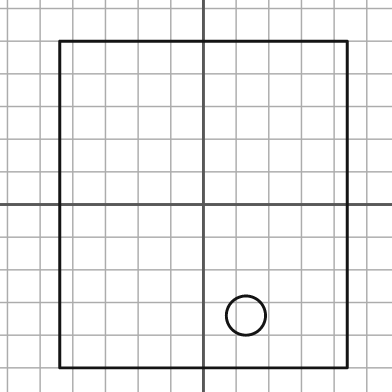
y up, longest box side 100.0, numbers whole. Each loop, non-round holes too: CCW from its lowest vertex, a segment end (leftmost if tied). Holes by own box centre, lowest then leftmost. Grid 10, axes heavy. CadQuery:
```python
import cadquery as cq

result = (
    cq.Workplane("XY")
    .moveTo(-44.0, -50.0)
    .lineTo(44.0, -50.0)
    .lineTo(44.0, 50.0)
    .lineTo(-44.0, 50.0)
    .close()
    .moveTo(13.0, -34.0)
    .circle(6.0)
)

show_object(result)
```